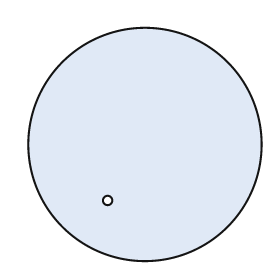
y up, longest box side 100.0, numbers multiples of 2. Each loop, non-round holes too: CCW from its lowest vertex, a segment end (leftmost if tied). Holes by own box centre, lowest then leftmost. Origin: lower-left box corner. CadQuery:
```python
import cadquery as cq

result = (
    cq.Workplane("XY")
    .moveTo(50.0, 50.0)
    .circle(50.0)
    .moveTo(34.0, 26.0)
    .circle(2.0)
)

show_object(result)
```